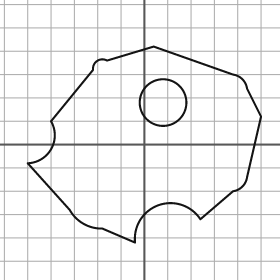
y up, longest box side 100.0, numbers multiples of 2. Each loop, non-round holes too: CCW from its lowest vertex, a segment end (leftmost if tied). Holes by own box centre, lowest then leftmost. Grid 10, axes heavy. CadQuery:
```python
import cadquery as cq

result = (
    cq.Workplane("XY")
    .moveTo(-4.0, -42.0)
    .threePointArc((6.0, -26.0), (24.0, -32.0))
    .lineTo(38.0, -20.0)
    .threePointArc((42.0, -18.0), (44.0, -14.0))
    .lineTo(50.0, 12.0)
    .lineTo(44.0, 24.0)
    .threePointArc((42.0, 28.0), (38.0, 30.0))
    .lineTo(4.0, 42.0)
    .lineTo(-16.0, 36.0)
    .threePointArc((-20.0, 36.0), (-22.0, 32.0))
    .lineTo(-40.0, 10.0)
    .threePointArc((-40.0, -2.0), (-50.0, -8.0))
    .lineTo(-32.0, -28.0)
    .threePointArc((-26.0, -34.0), (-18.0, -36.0))
    .close()
    .moveTo(8.0, 18.0)
    .circle(10.0)
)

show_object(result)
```